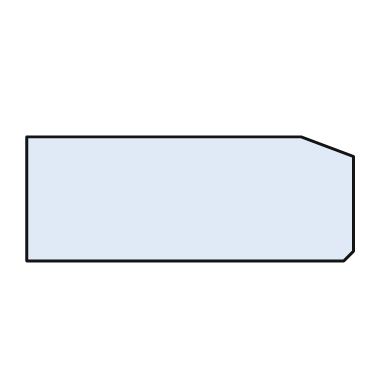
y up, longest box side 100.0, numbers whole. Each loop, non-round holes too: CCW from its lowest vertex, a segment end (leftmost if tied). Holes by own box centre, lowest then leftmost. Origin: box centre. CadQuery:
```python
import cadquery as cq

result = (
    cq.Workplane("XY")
    .moveTo(-50.0, -19.0)
    .lineTo(47.0, -19.0)
    .lineTo(50.0, -16.0)
    .lineTo(50.0, 13.0)
    .lineTo(34.0, 19.0)
    .lineTo(-50.0, 19.0)
    .close()
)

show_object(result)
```